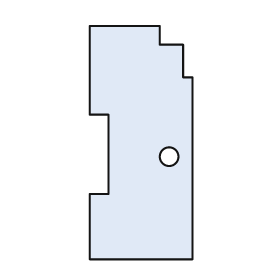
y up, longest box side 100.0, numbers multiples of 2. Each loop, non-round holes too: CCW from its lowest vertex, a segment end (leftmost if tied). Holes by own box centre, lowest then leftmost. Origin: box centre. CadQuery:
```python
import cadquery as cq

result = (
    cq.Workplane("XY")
    .moveTo(-22.0, -50.0)
    .lineTo(22.0, -50.0)
    .lineTo(22.0, 28.0)
    .lineTo(18.0, 28.0)
    .lineTo(18.0, 42.0)
    .lineTo(8.0, 42.0)
    .lineTo(8.0, 50.0)
    .lineTo(-22.0, 50.0)
    .lineTo(-22.0, 12.0)
    .lineTo(-14.0, 12.0)
    .lineTo(-14.0, -22.0)
    .lineTo(-22.0, -22.0)
    .close()
    .moveTo(12.0, -6.0)
    .circle(4.0)
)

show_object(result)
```